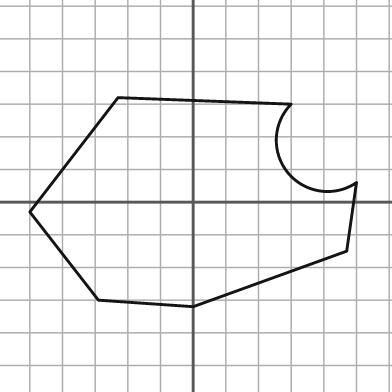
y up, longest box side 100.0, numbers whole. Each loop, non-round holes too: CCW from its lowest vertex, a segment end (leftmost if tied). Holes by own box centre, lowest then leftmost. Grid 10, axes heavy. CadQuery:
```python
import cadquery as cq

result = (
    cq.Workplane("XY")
    .moveTo(0.0, -32.0)
    .lineTo(47.0, -15.0)
    .lineTo(50.0, 6.0)
    .threePointArc((29.0, 9.0), (30.0, 30.0))
    .lineTo(-23.0, 32.0)
    .lineTo(-50.0, -3.0)
    .lineTo(-29.0, -30.0)
    .close()
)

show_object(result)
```